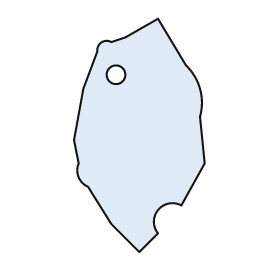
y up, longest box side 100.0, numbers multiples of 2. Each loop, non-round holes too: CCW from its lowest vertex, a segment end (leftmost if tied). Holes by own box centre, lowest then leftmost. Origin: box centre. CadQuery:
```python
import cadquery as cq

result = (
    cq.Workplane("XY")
    .moveTo(0.0, -50.0)
    .lineTo(8.0, -42.0)
    .threePointArc((8.0, -32.0), (18.0, -30.0))
    .lineTo(28.0, -12.0)
    .lineTo(26.0, 8.0)
    .threePointArc((26.0, 20.0), (20.0, 30.0))
    .lineTo(8.0, 50.0)
    .lineTo(-6.0, 42.0)
    .lineTo(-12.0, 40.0)
    .threePointArc((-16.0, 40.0), (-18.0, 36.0))
    .lineTo(-24.0, 20.0)
    .lineTo(-28.0, -2.0)
    .lineTo(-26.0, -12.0)
    .threePointArc((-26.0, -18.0), (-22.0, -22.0))
    .lineTo(-12.0, -38.0)
    .close()
    .moveTo(-10.0, 26.0)
    .circle(4.0)
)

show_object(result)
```